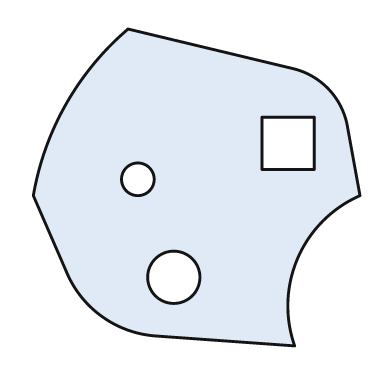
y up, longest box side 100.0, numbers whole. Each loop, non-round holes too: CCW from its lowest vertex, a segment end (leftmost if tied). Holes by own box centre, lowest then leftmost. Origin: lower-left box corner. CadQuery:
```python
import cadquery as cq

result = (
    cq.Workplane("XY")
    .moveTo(80.0, 0.0)
    .threePointArc((81.0, 27.0), (100.0, 46.0))
    .lineTo(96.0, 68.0)
    .threePointArc((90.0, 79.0), (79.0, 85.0))
    .lineTo(29.0, 97.0)
    .threePointArc((10.0, 74.0), (0.0, 46.0))
    .lineTo(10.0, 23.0)
    .threePointArc((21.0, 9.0), (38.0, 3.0))
    .close()
    .moveTo(43.0, 21.0)
    .circle(8.0)
    .moveTo(32.0, 51.0)
    .circle(5.0)
    .moveTo(70.0, 54.0)
    .lineTo(86.0, 54.0)
    .lineTo(86.0, 70.0)
    .lineTo(70.0, 70.0)
    .close()
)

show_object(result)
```